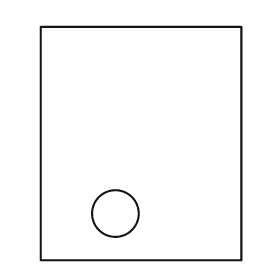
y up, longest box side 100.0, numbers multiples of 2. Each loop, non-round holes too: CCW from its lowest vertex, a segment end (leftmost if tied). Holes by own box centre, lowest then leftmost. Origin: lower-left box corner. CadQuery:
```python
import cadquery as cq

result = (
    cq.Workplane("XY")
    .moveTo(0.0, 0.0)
    .lineTo(86.0, 0.0)
    .lineTo(86.0, 100.0)
    .lineTo(0.0, 100.0)
    .close()
    .moveTo(32.0, 20.0)
    .circle(10.0)
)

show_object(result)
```